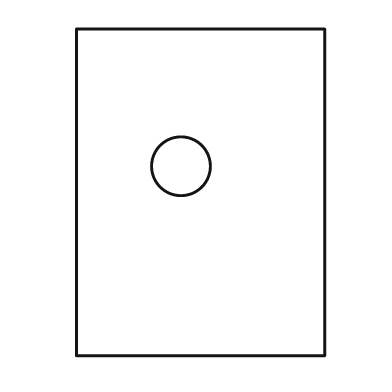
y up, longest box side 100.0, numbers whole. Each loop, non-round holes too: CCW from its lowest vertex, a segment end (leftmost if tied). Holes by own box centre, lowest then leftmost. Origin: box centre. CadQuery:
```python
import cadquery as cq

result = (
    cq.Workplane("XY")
    .moveTo(-38.0, -50.0)
    .lineTo(38.0, -50.0)
    .lineTo(38.0, 50.0)
    .lineTo(-38.0, 50.0)
    .close()
    .moveTo(-6.0, 8.0)
    .circle(9.0)
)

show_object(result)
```